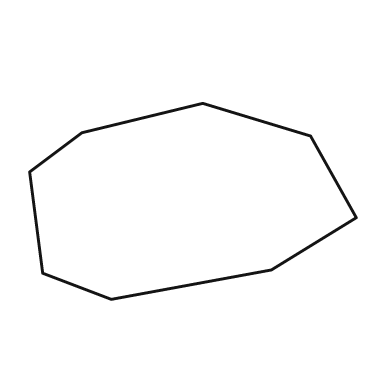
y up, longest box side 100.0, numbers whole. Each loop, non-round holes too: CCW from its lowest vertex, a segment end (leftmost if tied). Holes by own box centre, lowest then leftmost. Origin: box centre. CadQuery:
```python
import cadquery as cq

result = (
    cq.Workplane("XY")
    .moveTo(-25.0, -30.0)
    .lineTo(24.0, -21.0)
    .lineTo(50.0, -5.0)
    .lineTo(36.0, 20.0)
    .lineTo(3.0, 30.0)
    .lineTo(-34.0, 21.0)
    .lineTo(-50.0, 9.0)
    .lineTo(-46.0, -22.0)
    .close()
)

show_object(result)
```